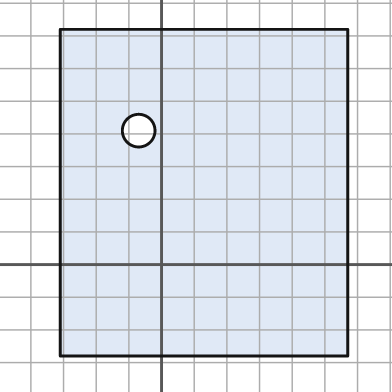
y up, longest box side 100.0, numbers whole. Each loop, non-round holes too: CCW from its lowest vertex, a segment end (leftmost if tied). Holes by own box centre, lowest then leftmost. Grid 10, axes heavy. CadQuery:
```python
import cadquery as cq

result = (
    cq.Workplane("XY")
    .moveTo(-31.0, -28.0)
    .lineTo(57.0, -28.0)
    .lineTo(57.0, 72.0)
    .lineTo(-31.0, 72.0)
    .close()
    .moveTo(-7.0, 41.0)
    .circle(5.0)
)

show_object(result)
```